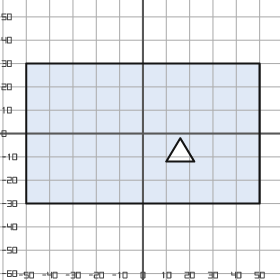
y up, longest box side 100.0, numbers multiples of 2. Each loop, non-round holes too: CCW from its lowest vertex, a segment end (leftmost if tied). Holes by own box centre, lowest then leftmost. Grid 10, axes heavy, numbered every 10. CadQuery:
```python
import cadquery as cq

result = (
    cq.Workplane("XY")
    .moveTo(-50.0, -30.0)
    .lineTo(50.0, -30.0)
    .lineTo(50.0, 30.0)
    .lineTo(-50.0, 30.0)
    .close()
    .moveTo(10.0, -12.0)
    .lineTo(22.0, -12.0)
    .lineTo(16.0, -2.0)
    .close()
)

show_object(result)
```